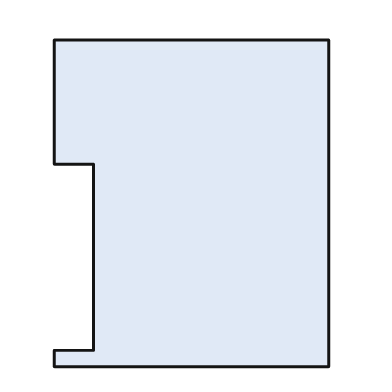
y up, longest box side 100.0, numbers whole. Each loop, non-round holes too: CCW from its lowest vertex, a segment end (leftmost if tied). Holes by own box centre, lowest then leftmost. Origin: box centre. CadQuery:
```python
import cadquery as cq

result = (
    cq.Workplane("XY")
    .moveTo(-42.0, -50.0)
    .lineTo(42.0, -50.0)
    .lineTo(42.0, 50.0)
    .lineTo(-42.0, 50.0)
    .lineTo(-42.0, 12.0)
    .lineTo(-30.0, 12.0)
    .lineTo(-30.0, -45.0)
    .lineTo(-42.0, -45.0)
    .close()
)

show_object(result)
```